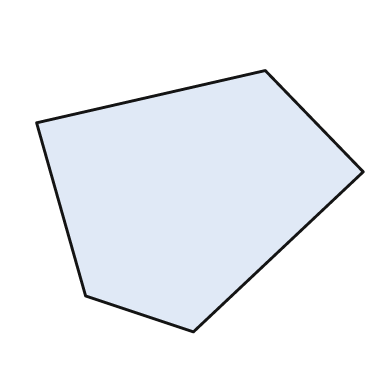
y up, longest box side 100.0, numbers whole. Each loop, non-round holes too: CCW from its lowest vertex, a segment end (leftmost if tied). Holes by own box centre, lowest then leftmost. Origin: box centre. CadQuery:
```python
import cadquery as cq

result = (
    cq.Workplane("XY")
    .moveTo(-2.0, -40.0)
    .lineTo(50.0, 9.0)
    .lineTo(20.0, 40.0)
    .lineTo(-50.0, 24.0)
    .lineTo(-35.0, -29.0)
    .close()
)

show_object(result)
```